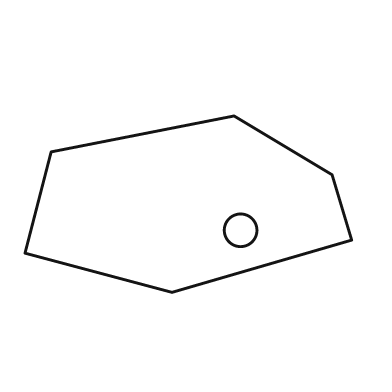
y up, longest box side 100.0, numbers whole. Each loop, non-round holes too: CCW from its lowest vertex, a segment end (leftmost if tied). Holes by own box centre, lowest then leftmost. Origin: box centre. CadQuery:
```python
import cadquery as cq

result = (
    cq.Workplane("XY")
    .moveTo(-5.0, -27.0)
    .lineTo(50.0, -11.0)
    .lineTo(44.0, 9.0)
    .lineTo(14.0, 27.0)
    .lineTo(-42.0, 16.0)
    .lineTo(-50.0, -15.0)
    .close()
    .moveTo(16.0, -8.0)
    .circle(5.0)
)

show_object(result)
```